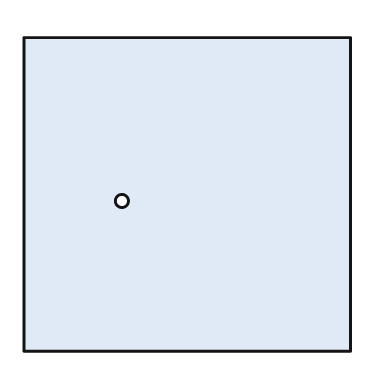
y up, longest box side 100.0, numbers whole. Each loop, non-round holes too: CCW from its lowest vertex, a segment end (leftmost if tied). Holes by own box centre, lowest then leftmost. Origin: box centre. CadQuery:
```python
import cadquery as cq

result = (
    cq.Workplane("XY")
    .moveTo(-50.0, -48.0)
    .lineTo(50.0, -48.0)
    .lineTo(50.0, 48.0)
    .lineTo(-50.0, 48.0)
    .close()
    .moveTo(-20.0, -2.0)
    .circle(2.0)
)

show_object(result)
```